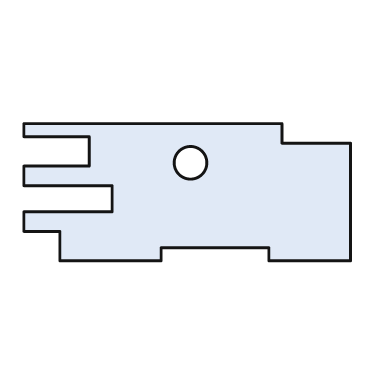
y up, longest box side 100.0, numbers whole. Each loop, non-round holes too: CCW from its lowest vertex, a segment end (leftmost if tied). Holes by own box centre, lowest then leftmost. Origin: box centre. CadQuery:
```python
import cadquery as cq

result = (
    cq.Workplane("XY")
    .moveTo(-39.0, -21.0)
    .lineTo(-8.0, -21.0)
    .lineTo(-8.0, -17.0)
    .lineTo(25.0, -17.0)
    .lineTo(25.0, -21.0)
    .lineTo(50.0, -21.0)
    .lineTo(50.0, 15.0)
    .lineTo(29.0, 15.0)
    .lineTo(29.0, 21.0)
    .lineTo(-50.0, 21.0)
    .lineTo(-50.0, 17.0)
    .lineTo(-30.0, 17.0)
    .lineTo(-30.0, 8.0)
    .lineTo(-50.0, 8.0)
    .lineTo(-50.0, 2.0)
    .lineTo(-23.0, 2.0)
    .lineTo(-23.0, -6.0)
    .lineTo(-50.0, -6.0)
    .lineTo(-50.0, -12.0)
    .lineTo(-39.0, -12.0)
    .close()
    .moveTo(1.0, 9.0)
    .circle(5.0)
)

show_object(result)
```